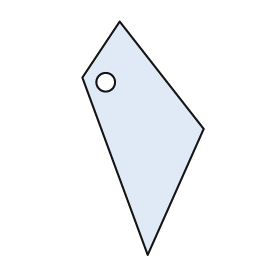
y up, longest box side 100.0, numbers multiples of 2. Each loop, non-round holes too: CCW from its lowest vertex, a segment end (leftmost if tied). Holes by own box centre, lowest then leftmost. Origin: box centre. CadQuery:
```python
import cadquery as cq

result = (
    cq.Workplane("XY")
    .moveTo(2.0, -50.0)
    .lineTo(26.0, 4.0)
    .lineTo(-10.0, 50.0)
    .lineTo(-26.0, 26.0)
    .close()
    .moveTo(-16.0, 24.0)
    .circle(4.0)
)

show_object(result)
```